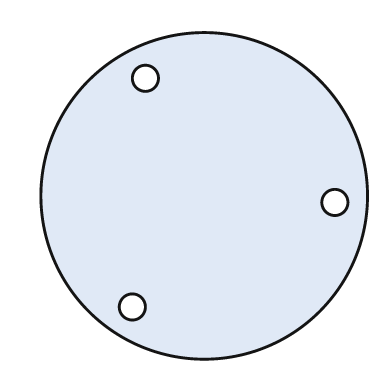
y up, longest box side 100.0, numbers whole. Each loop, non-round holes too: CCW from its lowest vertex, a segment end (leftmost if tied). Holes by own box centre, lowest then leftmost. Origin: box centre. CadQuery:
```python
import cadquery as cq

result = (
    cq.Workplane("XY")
    .moveTo(0.0, 0.0)
    .circle(50.0)
    .moveTo(-22.0, -34.0)
    .circle(4.0)
    .moveTo(40.0, -2.0)
    .circle(4.0)
    .moveTo(-18.0, 36.0)
    .circle(4.0)
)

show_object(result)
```